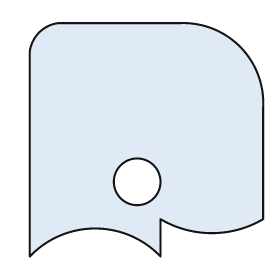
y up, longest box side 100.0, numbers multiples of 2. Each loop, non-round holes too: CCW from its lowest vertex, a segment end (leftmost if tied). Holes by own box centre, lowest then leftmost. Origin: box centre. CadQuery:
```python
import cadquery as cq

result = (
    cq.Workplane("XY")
    .moveTo(-50.0, -50.0)
    .threePointArc((-22.0, -38.0), (6.0, -50.0))
    .lineTo(6.0, -34.0)
    .threePointArc((28.0, -40.0), (50.0, -34.0))
    .lineTo(50.0, 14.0)
    .threePointArc((40.0, 40.0), (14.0, 50.0))
    .lineTo(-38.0, 50.0)
    .threePointArc((-46.0, 46.0), (-50.0, 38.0))
    .close()
    .moveTo(-4.0, -18.0)
    .circle(10.0)
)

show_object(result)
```